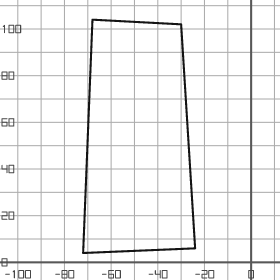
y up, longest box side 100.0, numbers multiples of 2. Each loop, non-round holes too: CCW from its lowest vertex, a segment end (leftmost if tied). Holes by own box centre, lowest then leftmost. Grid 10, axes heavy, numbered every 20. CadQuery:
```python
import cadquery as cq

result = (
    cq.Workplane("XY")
    .moveTo(-72.0, 4.0)
    .lineTo(-24.0, 6.0)
    .lineTo(-30.0, 102.0)
    .lineTo(-68.0, 104.0)
    .close()
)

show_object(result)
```